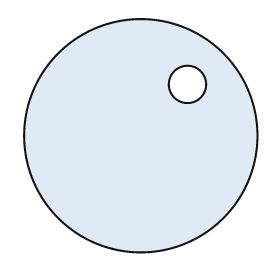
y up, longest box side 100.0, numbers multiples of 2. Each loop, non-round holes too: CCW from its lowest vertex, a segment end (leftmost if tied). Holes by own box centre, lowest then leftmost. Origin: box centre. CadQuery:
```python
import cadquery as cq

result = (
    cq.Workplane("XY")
    .moveTo(0.0, 0.0)
    .circle(50.0)
    .moveTo(20.0, 22.0)
    .circle(8.0)
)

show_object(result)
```